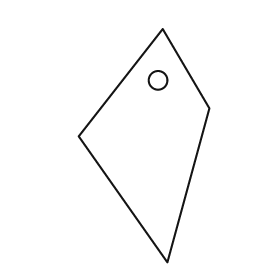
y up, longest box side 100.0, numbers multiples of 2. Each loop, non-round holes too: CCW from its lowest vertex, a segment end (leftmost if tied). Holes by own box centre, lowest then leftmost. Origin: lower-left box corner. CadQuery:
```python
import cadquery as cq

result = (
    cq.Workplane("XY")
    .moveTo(38.0, 0.0)
    .lineTo(56.0, 66.0)
    .lineTo(36.0, 100.0)
    .lineTo(0.0, 54.0)
    .close()
    .moveTo(34.0, 78.0)
    .circle(4.0)
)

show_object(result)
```